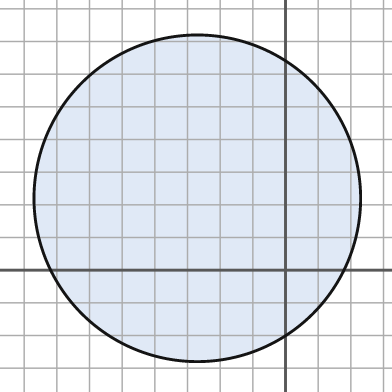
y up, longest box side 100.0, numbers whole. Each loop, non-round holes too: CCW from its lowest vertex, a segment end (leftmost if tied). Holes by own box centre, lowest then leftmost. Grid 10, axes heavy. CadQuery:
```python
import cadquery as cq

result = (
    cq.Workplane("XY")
    .moveTo(-27.0, 22.0)
    .circle(50.0)
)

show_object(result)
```